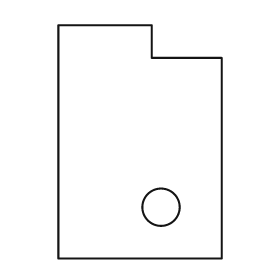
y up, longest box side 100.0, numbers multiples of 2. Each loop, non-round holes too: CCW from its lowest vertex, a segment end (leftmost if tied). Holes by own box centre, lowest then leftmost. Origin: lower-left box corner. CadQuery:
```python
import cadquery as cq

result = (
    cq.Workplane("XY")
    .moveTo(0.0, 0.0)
    .lineTo(70.0, 0.0)
    .lineTo(70.0, 86.0)
    .lineTo(40.0, 86.0)
    .lineTo(40.0, 100.0)
    .lineTo(0.0, 100.0)
    .close()
    .moveTo(44.0, 22.0)
    .circle(8.0)
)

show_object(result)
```